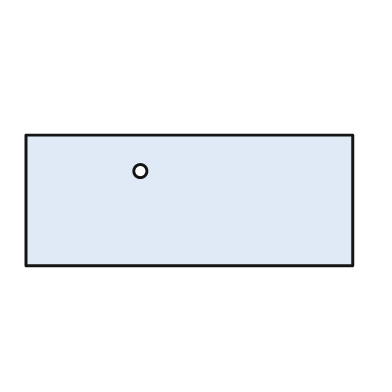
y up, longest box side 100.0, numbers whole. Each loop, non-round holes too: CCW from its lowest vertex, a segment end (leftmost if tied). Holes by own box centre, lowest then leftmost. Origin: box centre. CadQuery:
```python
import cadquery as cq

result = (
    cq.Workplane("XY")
    .moveTo(-50.0, -20.0)
    .lineTo(50.0, -20.0)
    .lineTo(50.0, 20.0)
    .lineTo(-50.0, 20.0)
    .close()
    .moveTo(-15.0, 9.0)
    .circle(2.0)
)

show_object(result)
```